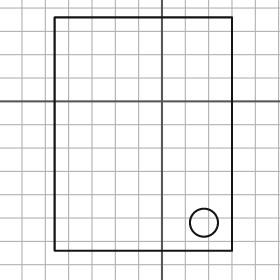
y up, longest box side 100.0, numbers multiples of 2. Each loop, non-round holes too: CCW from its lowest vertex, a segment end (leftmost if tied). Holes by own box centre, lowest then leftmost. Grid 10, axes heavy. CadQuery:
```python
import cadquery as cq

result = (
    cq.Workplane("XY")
    .moveTo(-46.0, -64.0)
    .lineTo(30.0, -64.0)
    .lineTo(30.0, 36.0)
    .lineTo(-46.0, 36.0)
    .close()
    .moveTo(18.0, -52.0)
    .circle(6.0)
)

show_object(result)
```